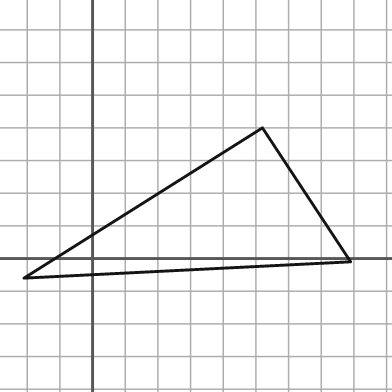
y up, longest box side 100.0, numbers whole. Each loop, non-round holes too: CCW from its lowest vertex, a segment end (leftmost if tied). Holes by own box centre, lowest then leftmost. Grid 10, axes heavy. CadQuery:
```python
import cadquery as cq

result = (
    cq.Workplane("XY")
    .moveTo(-21.0, -6.0)
    .lineTo(79.0, -1.0)
    .lineTo(52.0, 40.0)
    .close()
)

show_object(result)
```